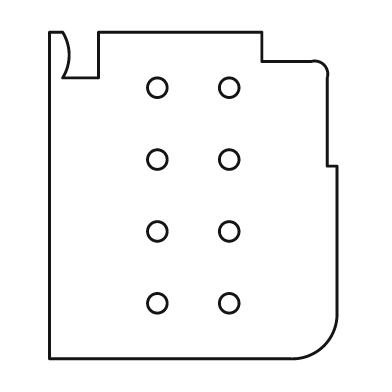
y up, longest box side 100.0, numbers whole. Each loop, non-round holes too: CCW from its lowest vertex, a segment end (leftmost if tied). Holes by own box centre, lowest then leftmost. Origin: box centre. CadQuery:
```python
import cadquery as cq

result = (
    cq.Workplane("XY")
    .moveTo(-44.0, -50.0)
    .lineTo(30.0, -50.0)
    .threePointArc((40.0, -46.0), (44.0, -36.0))
    .lineTo(44.0, 9.0)
    .lineTo(41.0, 9.0)
    .lineTo(41.0, 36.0)
    .threePointArc((40.0, 40.0), (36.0, 41.0))
    .lineTo(21.0, 41.0)
    .lineTo(21.0, 50.0)
    .lineTo(-29.0, 50.0)
    .lineTo(-29.0, 36.0)
    .lineTo(-40.0, 36.0)
    .threePointArc((-38.0, 43.0), (-40.0, 50.0))
    .lineTo(-44.0, 50.0)
    .close()
    .moveTo(-11.0, -33.0)
    .circle(3.0)
    .moveTo(11.0, -33.0)
    .circle(3.0)
    .moveTo(-11.0, -11.0)
    .circle(3.0)
    .moveTo(11.0, -11.0)
    .circle(3.0)
    .moveTo(-11.0, 11.0)
    .circle(3.0)
    .moveTo(11.0, 11.0)
    .circle(3.0)
    .moveTo(-11.0, 33.0)
    .circle(3.0)
    .moveTo(11.0, 33.0)
    .circle(3.0)
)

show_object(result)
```